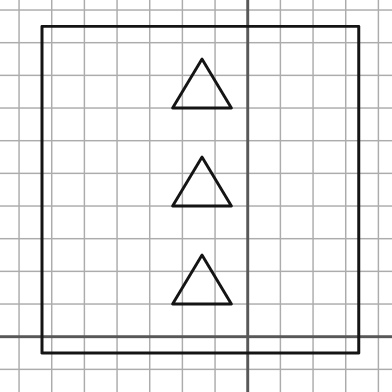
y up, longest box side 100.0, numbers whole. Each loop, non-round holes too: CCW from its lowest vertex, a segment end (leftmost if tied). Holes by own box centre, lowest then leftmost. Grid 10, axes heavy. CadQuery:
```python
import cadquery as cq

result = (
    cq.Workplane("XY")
    .moveTo(-63.0, -5.0)
    .lineTo(34.0, -5.0)
    .lineTo(34.0, 95.0)
    .lineTo(-63.0, 95.0)
    .close()
    .moveTo(-23.0, 10.0)
    .lineTo(-5.0, 10.0)
    .lineTo(-14.0, 25.0)
    .close()
    .moveTo(-23.0, 40.0)
    .lineTo(-5.0, 40.0)
    .lineTo(-14.0, 55.0)
    .close()
    .moveTo(-23.0, 70.0)
    .lineTo(-5.0, 70.0)
    .lineTo(-14.0, 85.0)
    .close()
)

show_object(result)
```